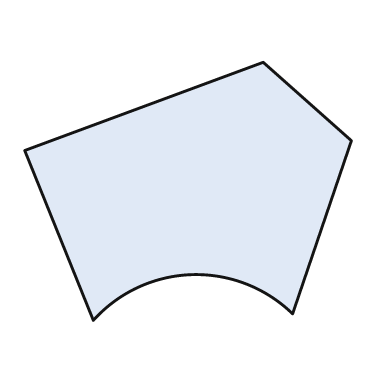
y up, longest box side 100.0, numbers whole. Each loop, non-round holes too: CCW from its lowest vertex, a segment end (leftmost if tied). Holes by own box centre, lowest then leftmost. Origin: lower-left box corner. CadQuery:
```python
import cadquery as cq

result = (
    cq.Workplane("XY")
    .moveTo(21.0, 0.0)
    .threePointArc((51.0, 14.0), (82.0, 2.0))
    .lineTo(100.0, 55.0)
    .lineTo(73.0, 79.0)
    .lineTo(0.0, 52.0)
    .close()
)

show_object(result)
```